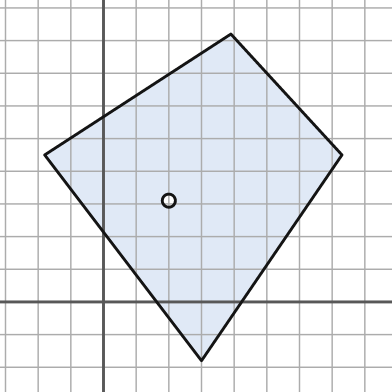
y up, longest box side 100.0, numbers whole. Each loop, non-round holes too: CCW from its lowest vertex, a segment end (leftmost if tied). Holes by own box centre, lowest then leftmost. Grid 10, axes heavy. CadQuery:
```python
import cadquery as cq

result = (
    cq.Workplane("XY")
    .moveTo(30.0, -18.0)
    .lineTo(73.0, 45.0)
    .lineTo(39.0, 82.0)
    .lineTo(-18.0, 45.0)
    .close()
    .moveTo(20.0, 31.0)
    .circle(2.0)
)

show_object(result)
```